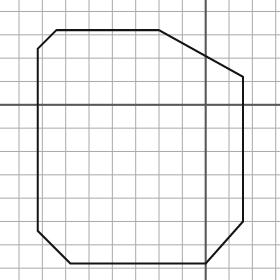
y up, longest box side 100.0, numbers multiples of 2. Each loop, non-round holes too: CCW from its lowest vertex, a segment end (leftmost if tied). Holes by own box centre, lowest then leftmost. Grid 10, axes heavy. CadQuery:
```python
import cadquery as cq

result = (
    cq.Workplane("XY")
    .moveTo(-58.0, -68.0)
    .lineTo(0.0, -68.0)
    .lineTo(16.0, -50.0)
    .lineTo(16.0, 12.0)
    .lineTo(-20.0, 32.0)
    .lineTo(-64.0, 32.0)
    .lineTo(-72.0, 24.0)
    .lineTo(-72.0, -54.0)
    .close()
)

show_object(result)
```